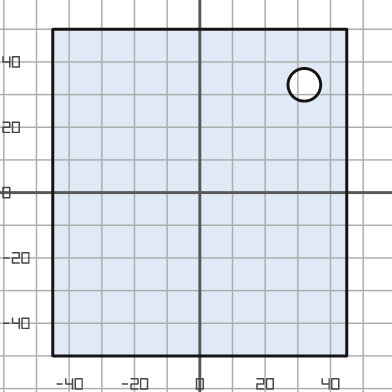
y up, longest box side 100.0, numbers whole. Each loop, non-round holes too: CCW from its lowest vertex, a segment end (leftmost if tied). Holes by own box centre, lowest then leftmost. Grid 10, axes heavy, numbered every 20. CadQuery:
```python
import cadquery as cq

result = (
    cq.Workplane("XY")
    .moveTo(-45.0, -50.0)
    .lineTo(45.0, -50.0)
    .lineTo(45.0, 50.0)
    .lineTo(-45.0, 50.0)
    .close()
    .moveTo(32.0, 33.0)
    .circle(5.0)
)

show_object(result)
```